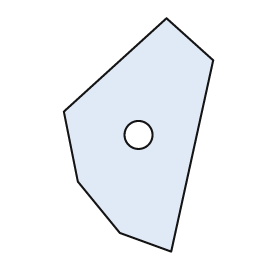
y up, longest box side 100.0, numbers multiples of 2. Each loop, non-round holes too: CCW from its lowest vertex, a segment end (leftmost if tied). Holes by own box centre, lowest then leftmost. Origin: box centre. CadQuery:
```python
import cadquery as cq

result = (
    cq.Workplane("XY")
    .moveTo(14.0, -50.0)
    .lineTo(32.0, 32.0)
    .lineTo(12.0, 50.0)
    .lineTo(-32.0, 10.0)
    .lineTo(-26.0, -20.0)
    .lineTo(-8.0, -42.0)
    .close()
    .moveTo(0.0, 0.0)
    .circle(6.0)
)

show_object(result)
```